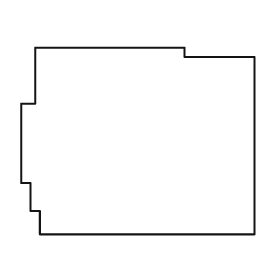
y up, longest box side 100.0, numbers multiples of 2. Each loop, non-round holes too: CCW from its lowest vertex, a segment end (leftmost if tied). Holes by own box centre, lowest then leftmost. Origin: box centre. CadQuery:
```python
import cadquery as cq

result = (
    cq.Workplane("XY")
    .moveTo(-42.0, -40.0)
    .lineTo(50.0, -40.0)
    .lineTo(50.0, 36.0)
    .lineTo(20.0, 36.0)
    .lineTo(20.0, 40.0)
    .lineTo(-44.0, 40.0)
    .lineTo(-44.0, 16.0)
    .lineTo(-50.0, 16.0)
    .lineTo(-50.0, -18.0)
    .lineTo(-46.0, -18.0)
    .lineTo(-46.0, -30.0)
    .lineTo(-42.0, -30.0)
    .close()
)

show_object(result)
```